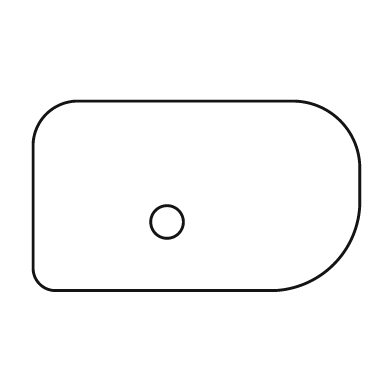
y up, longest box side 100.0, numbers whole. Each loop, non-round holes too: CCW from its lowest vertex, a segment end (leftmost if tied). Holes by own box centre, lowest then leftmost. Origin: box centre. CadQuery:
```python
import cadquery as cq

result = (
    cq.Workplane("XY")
    .moveTo(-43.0, -29.0)
    .lineTo(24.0, -29.0)
    .threePointArc((42.0, -21.0), (50.0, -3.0))
    .lineTo(50.0, 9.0)
    .threePointArc((44.0, 23.0), (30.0, 29.0))
    .lineTo(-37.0, 29.0)
    .threePointArc((-46.0, 25.0), (-50.0, 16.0))
    .lineTo(-50.0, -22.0)
    .threePointArc((-48.0, -27.0), (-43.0, -29.0))
    .close()
    .moveTo(-9.0, -8.0)
    .circle(5.0)
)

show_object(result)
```